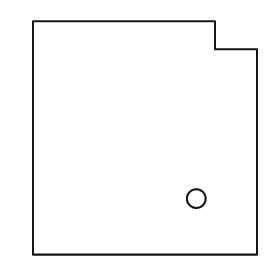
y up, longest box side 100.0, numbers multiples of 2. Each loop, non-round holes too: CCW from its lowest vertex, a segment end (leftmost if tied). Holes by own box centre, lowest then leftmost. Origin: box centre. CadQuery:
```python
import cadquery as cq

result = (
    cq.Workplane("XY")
    .moveTo(-48.0, -50.0)
    .lineTo(48.0, -50.0)
    .lineTo(48.0, 38.0)
    .lineTo(30.0, 38.0)
    .lineTo(30.0, 50.0)
    .lineTo(-48.0, 50.0)
    .close()
    .moveTo(22.0, -26.0)
    .circle(4.0)
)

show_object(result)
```